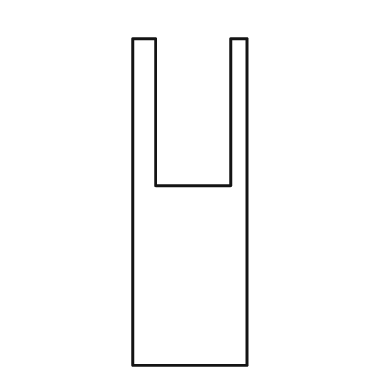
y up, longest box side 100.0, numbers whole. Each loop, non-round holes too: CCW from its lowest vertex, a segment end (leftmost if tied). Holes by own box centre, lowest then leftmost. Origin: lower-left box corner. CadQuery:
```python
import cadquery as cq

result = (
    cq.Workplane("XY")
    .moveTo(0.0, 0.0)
    .lineTo(35.0, 0.0)
    .lineTo(35.0, 100.0)
    .lineTo(30.0, 100.0)
    .lineTo(30.0, 55.0)
    .lineTo(7.0, 55.0)
    .lineTo(7.0, 100.0)
    .lineTo(0.0, 100.0)
    .close()
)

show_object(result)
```